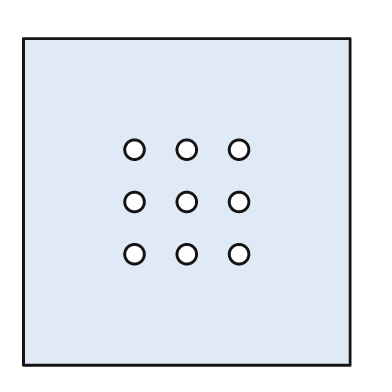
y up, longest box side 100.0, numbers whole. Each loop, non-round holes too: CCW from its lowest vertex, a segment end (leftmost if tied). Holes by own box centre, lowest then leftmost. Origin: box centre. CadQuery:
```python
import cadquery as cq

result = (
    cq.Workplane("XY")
    .moveTo(-50.0, -50.0)
    .lineTo(50.0, -50.0)
    .lineTo(50.0, 50.0)
    .lineTo(-50.0, 50.0)
    .close()
    .moveTo(-16.0, -16.0)
    .circle(3.0)
    .moveTo(0.0, -16.0)
    .circle(3.0)
    .moveTo(16.0, -16.0)
    .circle(3.0)
    .moveTo(-16.0, 0.0)
    .circle(3.0)
    .moveTo(0.0, 0.0)
    .circle(3.0)
    .moveTo(16.0, 0.0)
    .circle(3.0)
    .moveTo(-16.0, 16.0)
    .circle(3.0)
    .moveTo(0.0, 16.0)
    .circle(3.0)
    .moveTo(16.0, 16.0)
    .circle(3.0)
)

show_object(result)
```